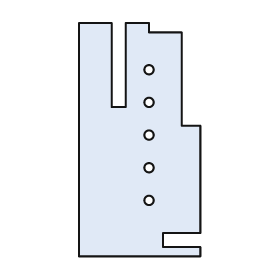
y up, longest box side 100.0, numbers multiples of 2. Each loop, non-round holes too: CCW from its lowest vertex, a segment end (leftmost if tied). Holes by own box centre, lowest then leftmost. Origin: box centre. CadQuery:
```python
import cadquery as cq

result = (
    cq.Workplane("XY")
    .moveTo(-26.0, -50.0)
    .lineTo(26.0, -50.0)
    .lineTo(26.0, -46.0)
    .lineTo(10.0, -46.0)
    .lineTo(10.0, -40.0)
    .lineTo(26.0, -40.0)
    .lineTo(26.0, 6.0)
    .lineTo(18.0, 6.0)
    .lineTo(18.0, 46.0)
    .lineTo(4.0, 46.0)
    .lineTo(4.0, 50.0)
    .lineTo(-6.0, 50.0)
    .lineTo(-6.0, 14.0)
    .lineTo(-12.0, 14.0)
    .lineTo(-12.0, 50.0)
    .lineTo(-26.0, 50.0)
    .close()
    .moveTo(4.0, -26.0)
    .circle(2.0)
    .moveTo(4.0, -12.0)
    .circle(2.0)
    .moveTo(4.0, 2.0)
    .circle(2.0)
    .moveTo(4.0, 16.0)
    .circle(2.0)
    .moveTo(4.0, 30.0)
    .circle(2.0)
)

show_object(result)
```